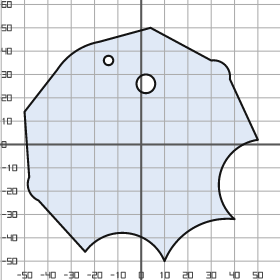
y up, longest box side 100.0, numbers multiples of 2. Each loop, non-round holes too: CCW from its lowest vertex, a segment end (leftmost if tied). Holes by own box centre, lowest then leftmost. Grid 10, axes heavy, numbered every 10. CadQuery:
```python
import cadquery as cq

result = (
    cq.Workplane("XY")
    .moveTo(10.0, -50.0)
    .threePointArc((22.0, -36.0), (40.0, -32.0))
    .threePointArc((34.0, -12.0), (50.0, 2.0))
    .lineTo(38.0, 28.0)
    .threePointArc((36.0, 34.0), (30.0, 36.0))
    .lineTo(4.0, 50.0)
    .lineTo(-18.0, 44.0)
    .threePointArc((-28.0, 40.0), (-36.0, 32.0))
    .lineTo(-50.0, 14.0)
    .lineTo(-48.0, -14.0)
    .threePointArc((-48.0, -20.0), (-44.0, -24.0))
    .lineTo(-24.0, -46.0)
    .threePointArc((-6.0, -38.0), (10.0, -50.0))
    .close()
    .moveTo(2.0, 26.0)
    .circle(4.0)
    .moveTo(-14.0, 36.0)
    .circle(2.0)
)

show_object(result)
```